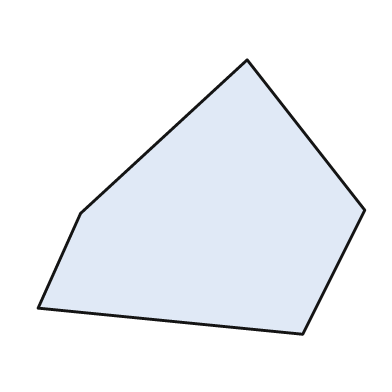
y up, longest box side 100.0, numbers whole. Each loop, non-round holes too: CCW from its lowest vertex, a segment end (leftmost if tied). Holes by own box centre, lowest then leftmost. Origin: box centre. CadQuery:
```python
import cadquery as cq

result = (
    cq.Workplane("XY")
    .moveTo(31.0, -42.0)
    .lineTo(50.0, -4.0)
    .lineTo(14.0, 42.0)
    .lineTo(-37.0, -5.0)
    .lineTo(-50.0, -34.0)
    .close()
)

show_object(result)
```